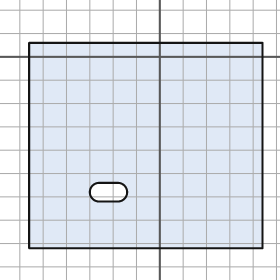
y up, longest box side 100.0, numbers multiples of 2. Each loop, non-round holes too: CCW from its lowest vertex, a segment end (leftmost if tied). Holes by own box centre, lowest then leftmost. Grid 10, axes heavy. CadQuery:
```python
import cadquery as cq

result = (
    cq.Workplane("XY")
    .moveTo(-56.0, -82.0)
    .lineTo(44.0, -82.0)
    .lineTo(44.0, 6.0)
    .lineTo(-56.0, 6.0)
    .close()
    .moveTo(-26.0, -62.0)
    .lineTo(-18.0, -62.0)
    .threePointArc((-14.0, -58.0), (-18.0, -54.0))
    .lineTo(-26.0, -54.0)
    .threePointArc((-30.0, -58.0), (-26.0, -62.0))
    .close()
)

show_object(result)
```